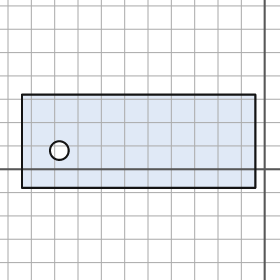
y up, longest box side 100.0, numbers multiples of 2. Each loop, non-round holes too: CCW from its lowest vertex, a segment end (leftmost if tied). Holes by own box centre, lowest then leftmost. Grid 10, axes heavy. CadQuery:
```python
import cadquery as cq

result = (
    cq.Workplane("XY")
    .moveTo(-104.0, -8.0)
    .lineTo(-4.0, -8.0)
    .lineTo(-4.0, 32.0)
    .lineTo(-104.0, 32.0)
    .close()
    .moveTo(-88.0, 8.0)
    .circle(4.0)
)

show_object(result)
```